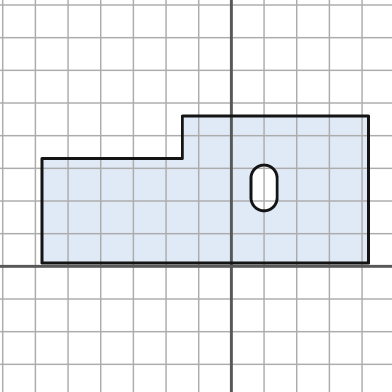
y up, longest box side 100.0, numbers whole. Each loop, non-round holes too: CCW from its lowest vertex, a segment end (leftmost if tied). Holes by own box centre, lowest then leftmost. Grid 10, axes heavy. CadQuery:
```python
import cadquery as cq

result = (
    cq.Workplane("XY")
    .moveTo(-58.0, 1.0)
    .lineTo(42.0, 1.0)
    .lineTo(42.0, 46.0)
    .lineTo(-15.0, 46.0)
    .lineTo(-15.0, 33.0)
    .lineTo(-58.0, 33.0)
    .close()
    .moveTo(6.0, 21.0)
    .threePointArc((10.0, 17.0), (14.0, 21.0))
    .lineTo(14.0, 27.0)
    .threePointArc((10.0, 31.0), (6.0, 27.0))
    .close()
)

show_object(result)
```